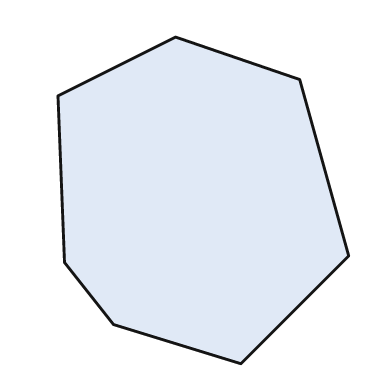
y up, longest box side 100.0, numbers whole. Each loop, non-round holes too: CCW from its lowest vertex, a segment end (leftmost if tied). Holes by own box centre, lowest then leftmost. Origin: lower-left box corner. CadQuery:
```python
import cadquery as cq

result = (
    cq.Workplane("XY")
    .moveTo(56.0, 0.0)
    .lineTo(89.0, 33.0)
    .lineTo(74.0, 87.0)
    .lineTo(36.0, 100.0)
    .lineTo(0.0, 82.0)
    .lineTo(2.0, 31.0)
    .lineTo(17.0, 12.0)
    .close()
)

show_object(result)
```